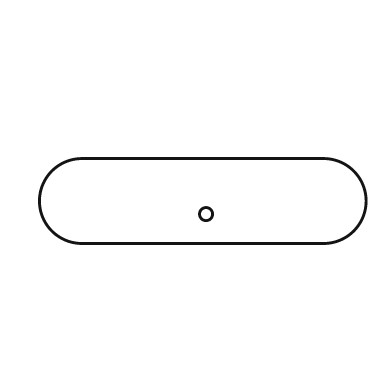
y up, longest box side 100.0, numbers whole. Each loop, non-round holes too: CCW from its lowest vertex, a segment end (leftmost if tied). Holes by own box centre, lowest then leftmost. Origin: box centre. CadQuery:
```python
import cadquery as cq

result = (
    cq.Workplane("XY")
    .moveTo(-37.0, -13.0)
    .lineTo(37.0, -13.0)
    .threePointArc((50.0, 0.0), (37.0, 13.0))
    .lineTo(-37.0, 13.0)
    .threePointArc((-50.0, 0.0), (-37.0, -13.0))
    .close()
    .moveTo(1.0, -4.0)
    .circle(2.0)
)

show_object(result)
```